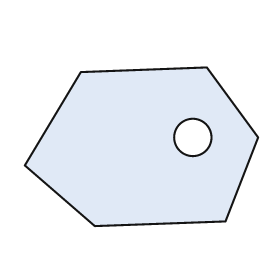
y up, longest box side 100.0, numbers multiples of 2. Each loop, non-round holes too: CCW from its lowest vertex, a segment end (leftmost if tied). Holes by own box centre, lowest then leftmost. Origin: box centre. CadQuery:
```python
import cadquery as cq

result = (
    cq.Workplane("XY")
    .moveTo(-20.0, -34.0)
    .lineTo(36.0, -32.0)
    .lineTo(50.0, 4.0)
    .lineTo(28.0, 34.0)
    .lineTo(-26.0, 32.0)
    .lineTo(-50.0, -8.0)
    .close()
    .moveTo(22.0, 4.0)
    .circle(8.0)
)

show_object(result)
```